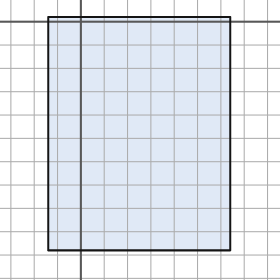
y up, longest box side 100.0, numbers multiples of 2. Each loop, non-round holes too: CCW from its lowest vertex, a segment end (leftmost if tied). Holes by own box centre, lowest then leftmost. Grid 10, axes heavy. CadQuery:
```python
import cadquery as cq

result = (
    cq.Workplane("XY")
    .moveTo(-14.0, -98.0)
    .lineTo(64.0, -98.0)
    .lineTo(64.0, 2.0)
    .lineTo(-14.0, 2.0)
    .close()
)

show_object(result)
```